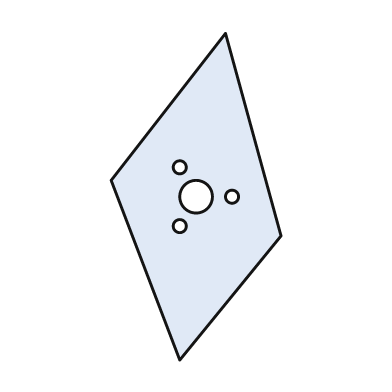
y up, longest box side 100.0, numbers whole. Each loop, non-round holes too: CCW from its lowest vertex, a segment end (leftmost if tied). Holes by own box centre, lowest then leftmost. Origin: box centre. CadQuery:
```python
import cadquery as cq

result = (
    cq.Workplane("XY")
    .moveTo(-5.0, -50.0)
    .lineTo(26.0, -12.0)
    .lineTo(9.0, 50.0)
    .lineTo(-26.0, 5.0)
    .close()
    .moveTo(-5.0, -9.0)
    .circle(2.0)
    .moveTo(0.0, 0.0)
    .circle(5.0)
    .moveTo(11.0, 0.0)
    .circle(2.0)
    .moveTo(-5.0, 9.0)
    .circle(2.0)
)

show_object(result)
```